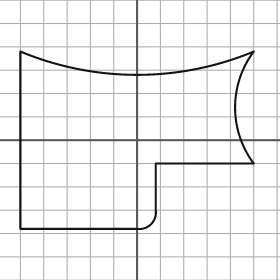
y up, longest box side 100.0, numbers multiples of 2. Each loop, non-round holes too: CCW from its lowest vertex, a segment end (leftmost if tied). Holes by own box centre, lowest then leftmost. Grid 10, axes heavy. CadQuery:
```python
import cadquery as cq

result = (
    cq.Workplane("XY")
    .moveTo(-50.0, -38.0)
    .lineTo(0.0, -38.0)
    .threePointArc((6.0, -36.0), (8.0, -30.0))
    .lineTo(8.0, -10.0)
    .lineTo(50.0, -10.0)
    .threePointArc((42.0, 14.0), (50.0, 38.0))
    .threePointArc((0.0, 28.0), (-50.0, 38.0))
    .close()
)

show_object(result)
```